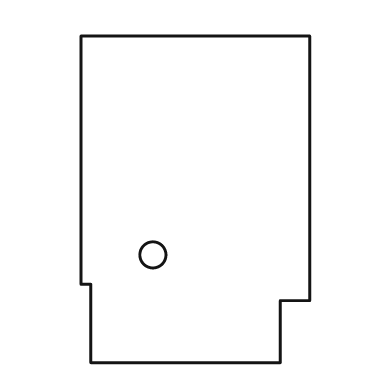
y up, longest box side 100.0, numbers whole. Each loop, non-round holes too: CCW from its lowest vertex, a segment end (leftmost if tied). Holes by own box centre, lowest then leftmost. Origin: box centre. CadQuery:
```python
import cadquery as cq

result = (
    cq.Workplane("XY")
    .moveTo(-32.0, -50.0)
    .lineTo(26.0, -50.0)
    .lineTo(26.0, -31.0)
    .lineTo(35.0, -31.0)
    .lineTo(35.0, 50.0)
    .lineTo(-35.0, 50.0)
    .lineTo(-35.0, -26.0)
    .lineTo(-32.0, -26.0)
    .close()
    .moveTo(-13.0, -17.0)
    .circle(4.0)
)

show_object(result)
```